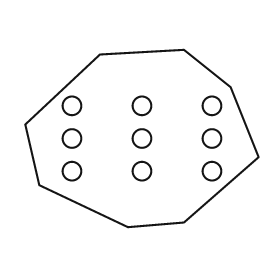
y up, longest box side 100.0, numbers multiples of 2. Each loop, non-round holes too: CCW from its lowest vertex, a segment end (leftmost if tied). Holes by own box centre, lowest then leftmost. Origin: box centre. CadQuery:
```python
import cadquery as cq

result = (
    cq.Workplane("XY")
    .moveTo(-6.0, -38.0)
    .lineTo(18.0, -36.0)
    .lineTo(50.0, -8.0)
    .lineTo(38.0, 22.0)
    .lineTo(18.0, 38.0)
    .lineTo(-18.0, 36.0)
    .lineTo(-50.0, 6.0)
    .lineTo(-44.0, -20.0)
    .close()
    .moveTo(-30.0, -14.0)
    .circle(4.0)
    .moveTo(0.0, -14.0)
    .circle(4.0)
    .moveTo(30.0, -14.0)
    .circle(4.0)
    .moveTo(-30.0, 0.0)
    .circle(4.0)
    .moveTo(0.0, 0.0)
    .circle(4.0)
    .moveTo(30.0, 0.0)
    .circle(4.0)
    .moveTo(-30.0, 14.0)
    .circle(4.0)
    .moveTo(0.0, 14.0)
    .circle(4.0)
    .moveTo(30.0, 14.0)
    .circle(4.0)
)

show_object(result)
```